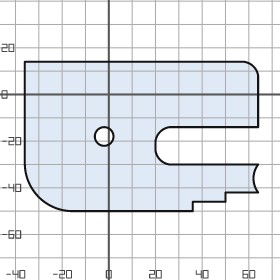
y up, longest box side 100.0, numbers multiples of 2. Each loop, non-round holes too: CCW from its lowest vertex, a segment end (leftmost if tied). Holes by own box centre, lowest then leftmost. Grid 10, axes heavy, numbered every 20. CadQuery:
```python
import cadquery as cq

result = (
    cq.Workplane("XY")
    .moveTo(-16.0, -50.0)
    .lineTo(36.0, -50.0)
    .lineTo(36.0, -46.0)
    .lineTo(50.0, -46.0)
    .lineTo(50.0, -42.0)
    .lineTo(64.0, -42.0)
    .threePointArc((62.0, -36.0), (64.0, -30.0))
    .lineTo(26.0, -30.0)
    .threePointArc((22.0, -28.0), (20.0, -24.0))
    .lineTo(20.0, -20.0)
    .threePointArc((22.0, -16.0), (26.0, -14.0))
    .lineTo(64.0, -14.0)
    .lineTo(64.0, 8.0)
    .threePointArc((62.0, 12.0), (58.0, 14.0))
    .lineTo(-36.0, 14.0)
    .lineTo(-36.0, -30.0)
    .threePointArc((-30.0, -44.0), (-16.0, -50.0))
    .close()
    .moveTo(-2.0, -18.0)
    .circle(4.0)
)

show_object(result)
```